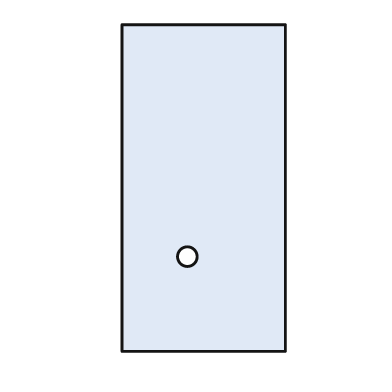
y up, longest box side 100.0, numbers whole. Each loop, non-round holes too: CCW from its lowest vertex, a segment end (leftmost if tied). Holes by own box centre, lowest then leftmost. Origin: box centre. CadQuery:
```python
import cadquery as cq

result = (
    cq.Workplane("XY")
    .moveTo(-25.0, -50.0)
    .lineTo(25.0, -50.0)
    .lineTo(25.0, 50.0)
    .lineTo(-25.0, 50.0)
    .close()
    .moveTo(-5.0, -21.0)
    .circle(3.0)
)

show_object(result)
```